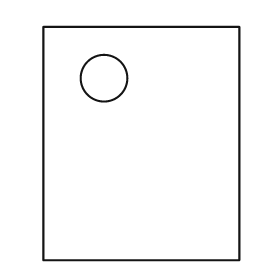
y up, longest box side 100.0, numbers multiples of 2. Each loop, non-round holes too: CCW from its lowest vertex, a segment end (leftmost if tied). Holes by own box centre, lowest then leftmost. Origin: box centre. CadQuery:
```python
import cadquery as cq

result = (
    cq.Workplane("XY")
    .moveTo(-42.0, -50.0)
    .lineTo(42.0, -50.0)
    .lineTo(42.0, 50.0)
    .lineTo(-42.0, 50.0)
    .close()
    .moveTo(-16.0, 28.0)
    .circle(10.0)
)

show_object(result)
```